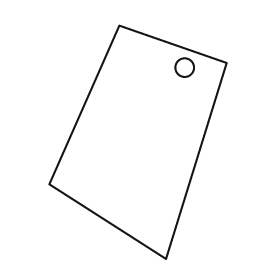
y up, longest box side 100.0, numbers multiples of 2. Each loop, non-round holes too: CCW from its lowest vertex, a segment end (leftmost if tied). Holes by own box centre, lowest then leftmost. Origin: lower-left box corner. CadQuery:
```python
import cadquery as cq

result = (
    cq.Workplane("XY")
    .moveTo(50.0, 0.0)
    .lineTo(76.0, 84.0)
    .lineTo(30.0, 100.0)
    .lineTo(0.0, 32.0)
    .close()
    .moveTo(58.0, 82.0)
    .circle(4.0)
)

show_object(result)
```